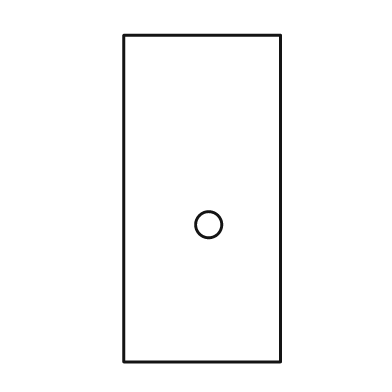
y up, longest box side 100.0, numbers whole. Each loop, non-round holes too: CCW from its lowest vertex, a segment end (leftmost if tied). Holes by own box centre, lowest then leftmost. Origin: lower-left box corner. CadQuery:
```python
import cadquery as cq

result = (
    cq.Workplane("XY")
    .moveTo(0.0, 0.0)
    .lineTo(48.0, 0.0)
    .lineTo(48.0, 100.0)
    .lineTo(0.0, 100.0)
    .close()
    .moveTo(26.0, 42.0)
    .circle(4.0)
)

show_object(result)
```